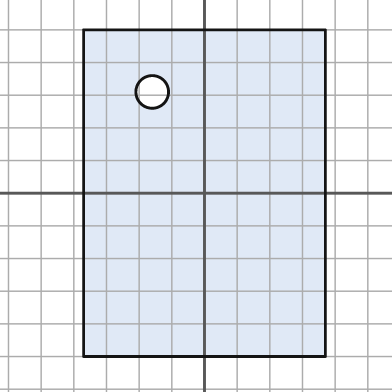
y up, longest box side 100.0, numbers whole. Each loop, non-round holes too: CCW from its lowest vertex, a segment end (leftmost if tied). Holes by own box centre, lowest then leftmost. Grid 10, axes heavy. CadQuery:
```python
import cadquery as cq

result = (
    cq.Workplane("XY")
    .moveTo(-37.0, -50.0)
    .lineTo(37.0, -50.0)
    .lineTo(37.0, 50.0)
    .lineTo(-37.0, 50.0)
    .close()
    .moveTo(-16.0, 31.0)
    .circle(5.0)
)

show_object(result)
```